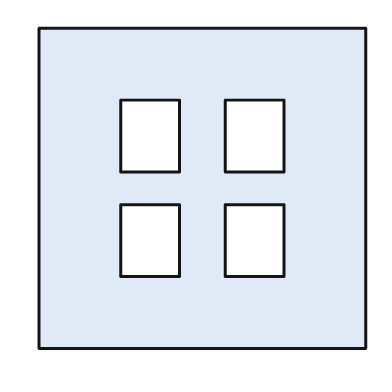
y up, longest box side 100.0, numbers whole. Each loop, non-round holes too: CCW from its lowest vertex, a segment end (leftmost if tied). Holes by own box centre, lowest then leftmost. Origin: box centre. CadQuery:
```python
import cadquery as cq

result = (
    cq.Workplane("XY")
    .moveTo(-50.0, -49.0)
    .lineTo(50.0, -49.0)
    .lineTo(50.0, 49.0)
    .lineTo(-50.0, 49.0)
    .close()
    .moveTo(-25.0, -27.0)
    .lineTo(-7.0, -27.0)
    .lineTo(-7.0, -5.0)
    .lineTo(-25.0, -5.0)
    .close()
    .moveTo(7.0, -27.0)
    .lineTo(25.0, -27.0)
    .lineTo(25.0, -5.0)
    .lineTo(7.0, -5.0)
    .close()
    .moveTo(-25.0, 5.0)
    .lineTo(-7.0, 5.0)
    .lineTo(-7.0, 27.0)
    .lineTo(-25.0, 27.0)
    .close()
    .moveTo(7.0, 5.0)
    .lineTo(25.0, 5.0)
    .lineTo(25.0, 27.0)
    .lineTo(7.0, 27.0)
    .close()
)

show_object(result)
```